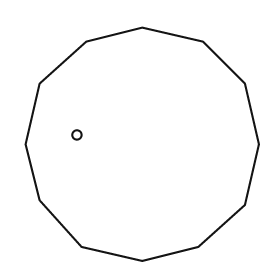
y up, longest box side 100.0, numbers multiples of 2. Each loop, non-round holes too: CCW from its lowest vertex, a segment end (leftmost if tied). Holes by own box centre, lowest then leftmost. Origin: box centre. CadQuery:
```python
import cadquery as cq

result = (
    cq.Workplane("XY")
    .moveTo(0.0, -50.0)
    .lineTo(24.0, -44.0)
    .lineTo(44.0, -26.0)
    .lineTo(50.0, 0.0)
    .lineTo(44.0, 26.0)
    .lineTo(26.0, 44.0)
    .lineTo(0.0, 50.0)
    .lineTo(-24.0, 44.0)
    .lineTo(-44.0, 26.0)
    .lineTo(-50.0, 0.0)
    .lineTo(-44.0, -24.0)
    .lineTo(-26.0, -44.0)
    .close()
    .moveTo(-28.0, 4.0)
    .circle(2.0)
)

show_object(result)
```